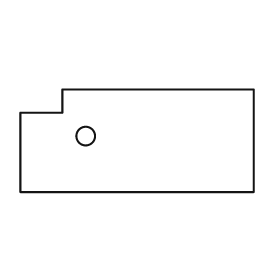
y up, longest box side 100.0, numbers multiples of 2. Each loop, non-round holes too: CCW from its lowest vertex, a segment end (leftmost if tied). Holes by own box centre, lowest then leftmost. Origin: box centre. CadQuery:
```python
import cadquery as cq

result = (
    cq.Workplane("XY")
    .moveTo(-50.0, -22.0)
    .lineTo(50.0, -22.0)
    .lineTo(50.0, 22.0)
    .lineTo(-32.0, 22.0)
    .lineTo(-32.0, 12.0)
    .lineTo(-50.0, 12.0)
    .close()
    .moveTo(-22.0, 2.0)
    .circle(4.0)
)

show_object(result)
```